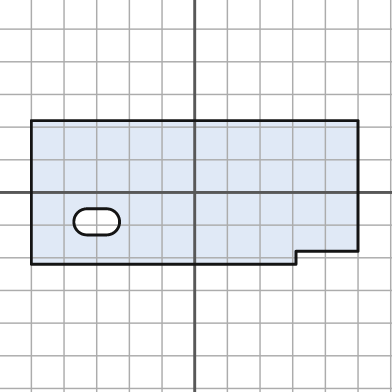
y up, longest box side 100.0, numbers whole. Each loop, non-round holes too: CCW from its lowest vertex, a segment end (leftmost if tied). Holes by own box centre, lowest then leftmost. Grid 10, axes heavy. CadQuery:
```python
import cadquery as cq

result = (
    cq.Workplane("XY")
    .moveTo(-50.0, -22.0)
    .lineTo(31.0, -22.0)
    .lineTo(31.0, -18.0)
    .lineTo(50.0, -18.0)
    .lineTo(50.0, 22.0)
    .lineTo(-50.0, 22.0)
    .close()
    .moveTo(-33.0, -13.0)
    .lineTo(-27.0, -13.0)
    .threePointArc((-23.0, -9.0), (-27.0, -5.0))
    .lineTo(-33.0, -5.0)
    .threePointArc((-37.0, -9.0), (-33.0, -13.0))
    .close()
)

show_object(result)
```